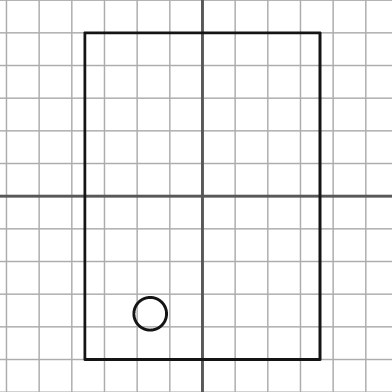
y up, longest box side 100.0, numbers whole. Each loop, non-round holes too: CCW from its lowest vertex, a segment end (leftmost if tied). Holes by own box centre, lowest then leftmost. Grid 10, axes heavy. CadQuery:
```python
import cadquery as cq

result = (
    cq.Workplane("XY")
    .moveTo(-36.0, -50.0)
    .lineTo(36.0, -50.0)
    .lineTo(36.0, 50.0)
    .lineTo(-36.0, 50.0)
    .close()
    .moveTo(-16.0, -36.0)
    .circle(5.0)
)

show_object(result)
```